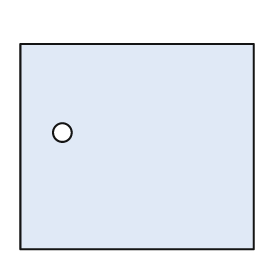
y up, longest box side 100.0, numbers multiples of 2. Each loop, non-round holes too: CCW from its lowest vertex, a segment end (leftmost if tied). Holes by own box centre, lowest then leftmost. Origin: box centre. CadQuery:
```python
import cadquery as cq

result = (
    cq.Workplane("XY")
    .moveTo(-50.0, -44.0)
    .lineTo(50.0, -44.0)
    .lineTo(50.0, 44.0)
    .lineTo(-50.0, 44.0)
    .close()
    .moveTo(-32.0, 6.0)
    .circle(4.0)
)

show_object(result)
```